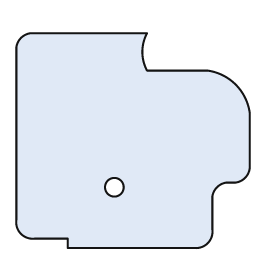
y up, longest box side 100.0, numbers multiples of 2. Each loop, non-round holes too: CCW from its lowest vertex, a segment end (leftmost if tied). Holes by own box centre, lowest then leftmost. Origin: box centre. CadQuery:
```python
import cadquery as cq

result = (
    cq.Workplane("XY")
    .moveTo(-28.0, -46.0)
    .lineTo(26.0, -46.0)
    .threePointArc((32.0, -44.0), (34.0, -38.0))
    .lineTo(34.0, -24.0)
    .threePointArc((36.0, -20.0), (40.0, -18.0))
    .lineTo(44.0, -18.0)
    .threePointArc((48.0, -16.0), (50.0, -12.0))
    .lineTo(50.0, 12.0)
    .threePointArc((44.0, 24.0), (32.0, 30.0))
    .lineTo(6.0, 30.0)
    .threePointArc((4.0, 38.0), (6.0, 46.0))
    .lineTo(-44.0, 46.0)
    .threePointArc((-48.0, 44.0), (-50.0, 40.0))
    .lineTo(-50.0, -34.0)
    .threePointArc((-48.0, -40.0), (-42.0, -42.0))
    .lineTo(-28.0, -42.0)
    .close()
    .moveTo(-8.0, -20.0)
    .circle(4.0)
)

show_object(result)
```